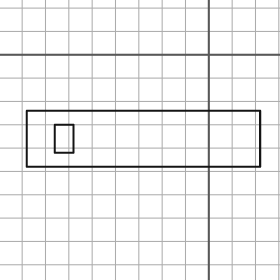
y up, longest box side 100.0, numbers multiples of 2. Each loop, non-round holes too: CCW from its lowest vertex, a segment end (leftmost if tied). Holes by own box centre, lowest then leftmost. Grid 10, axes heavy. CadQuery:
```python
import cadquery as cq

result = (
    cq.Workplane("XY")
    .moveTo(-78.0, -48.0)
    .lineTo(22.0, -48.0)
    .lineTo(22.0, -24.0)
    .lineTo(-78.0, -24.0)
    .close()
    .moveTo(-66.0, -42.0)
    .lineTo(-58.0, -42.0)
    .lineTo(-58.0, -30.0)
    .lineTo(-66.0, -30.0)
    .close()
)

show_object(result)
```